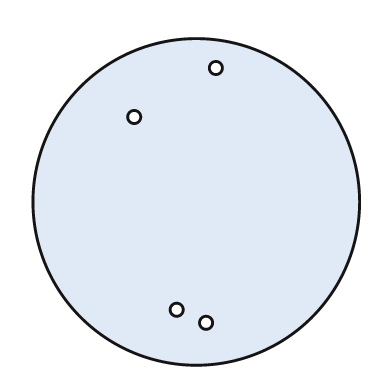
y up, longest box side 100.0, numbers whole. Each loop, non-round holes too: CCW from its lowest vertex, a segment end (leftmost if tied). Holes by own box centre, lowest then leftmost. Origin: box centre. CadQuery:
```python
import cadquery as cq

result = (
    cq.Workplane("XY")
    .moveTo(0.0, 0.0)
    .circle(50.0)
    .moveTo(3.0, -37.0)
    .circle(2.0)
    .moveTo(-6.0, -33.0)
    .circle(2.0)
    .moveTo(-19.0, 26.0)
    .circle(2.0)
    .moveTo(6.0, 41.0)
    .circle(2.0)
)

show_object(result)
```